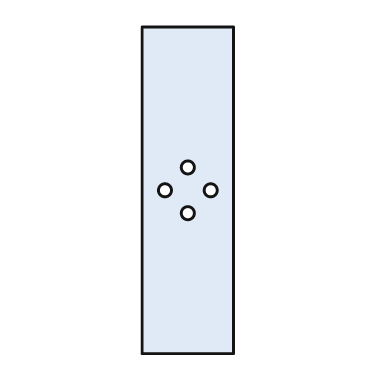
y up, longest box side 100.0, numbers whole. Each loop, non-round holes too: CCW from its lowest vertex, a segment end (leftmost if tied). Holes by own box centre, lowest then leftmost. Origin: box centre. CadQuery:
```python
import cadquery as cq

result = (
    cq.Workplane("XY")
    .moveTo(-14.0, -50.0)
    .lineTo(14.0, -50.0)
    .lineTo(14.0, 50.0)
    .lineTo(-14.0, 50.0)
    .close()
    .moveTo(0.0, -7.0)
    .circle(2.0)
    .moveTo(-7.0, 0.0)
    .circle(2.0)
    .moveTo(7.0, 0.0)
    .circle(2.0)
    .moveTo(0.0, 7.0)
    .circle(2.0)
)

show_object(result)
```